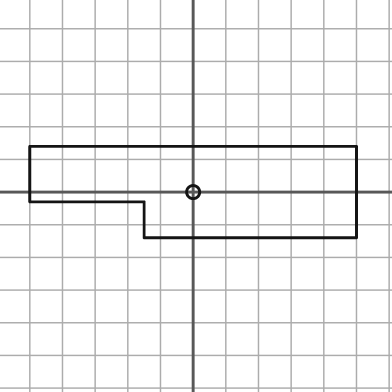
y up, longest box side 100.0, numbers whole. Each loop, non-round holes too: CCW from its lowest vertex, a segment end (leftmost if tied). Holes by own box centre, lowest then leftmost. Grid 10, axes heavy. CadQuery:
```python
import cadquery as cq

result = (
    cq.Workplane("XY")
    .moveTo(-15.0, -14.0)
    .lineTo(50.0, -14.0)
    .lineTo(50.0, 14.0)
    .lineTo(-50.0, 14.0)
    .lineTo(-50.0, -3.0)
    .lineTo(-15.0, -3.0)
    .close()
    .moveTo(0.0, 0.0)
    .circle(2.0)
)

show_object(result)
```